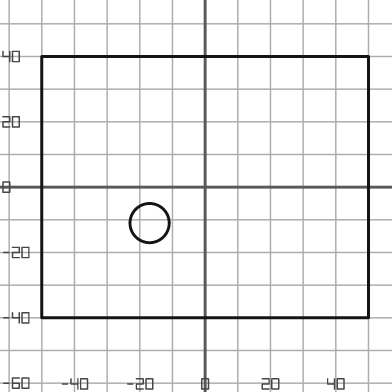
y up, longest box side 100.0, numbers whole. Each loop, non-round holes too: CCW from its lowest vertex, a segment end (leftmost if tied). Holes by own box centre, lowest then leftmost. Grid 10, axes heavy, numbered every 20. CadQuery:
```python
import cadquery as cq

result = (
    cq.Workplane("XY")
    .moveTo(-50.0, -40.0)
    .lineTo(50.0, -40.0)
    .lineTo(50.0, 40.0)
    .lineTo(-50.0, 40.0)
    .close()
    .moveTo(-17.0, -11.0)
    .circle(6.0)
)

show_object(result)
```